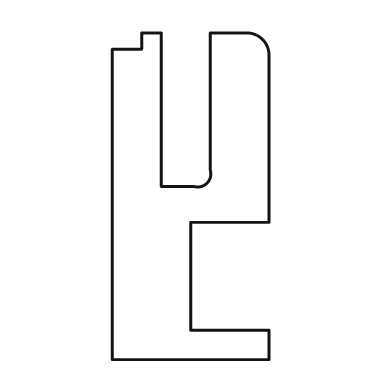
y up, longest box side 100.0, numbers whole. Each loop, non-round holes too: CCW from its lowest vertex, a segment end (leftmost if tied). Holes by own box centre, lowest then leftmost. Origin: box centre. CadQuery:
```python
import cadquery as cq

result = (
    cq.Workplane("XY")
    .moveTo(-24.0, -50.0)
    .lineTo(24.0, -50.0)
    .lineTo(24.0, -41.0)
    .lineTo(0.0, -41.0)
    .lineTo(0.0, -8.0)
    .lineTo(24.0, -8.0)
    .lineTo(24.0, 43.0)
    .threePointArc((22.0, 48.0), (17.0, 50.0))
    .lineTo(6.0, 50.0)
    .lineTo(6.0, 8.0)
    .threePointArc((5.0, 4.0), (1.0, 3.0))
    .lineTo(-9.0, 3.0)
    .lineTo(-9.0, 50.0)
    .lineTo(-15.0, 50.0)
    .lineTo(-15.0, 45.0)
    .lineTo(-24.0, 45.0)
    .close()
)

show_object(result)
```